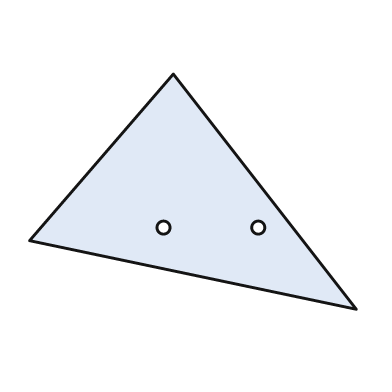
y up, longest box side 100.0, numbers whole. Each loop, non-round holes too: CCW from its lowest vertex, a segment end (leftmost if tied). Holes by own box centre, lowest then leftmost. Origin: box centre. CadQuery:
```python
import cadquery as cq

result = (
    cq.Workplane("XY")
    .moveTo(50.0, -36.0)
    .lineTo(-6.0, 36.0)
    .lineTo(-50.0, -15.0)
    .close()
    .moveTo(-9.0, -11.0)
    .circle(2.0)
    .moveTo(20.0, -11.0)
    .circle(2.0)
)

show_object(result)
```